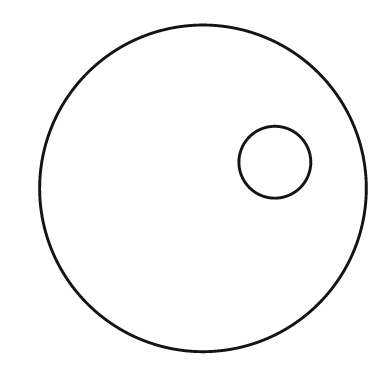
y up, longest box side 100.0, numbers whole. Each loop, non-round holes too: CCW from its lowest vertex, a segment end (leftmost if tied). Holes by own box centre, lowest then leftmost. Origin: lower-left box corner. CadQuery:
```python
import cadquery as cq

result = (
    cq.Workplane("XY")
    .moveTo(50.0, 50.0)
    .circle(50.0)
    .moveTo(72.0, 58.0)
    .circle(11.0)
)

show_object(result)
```